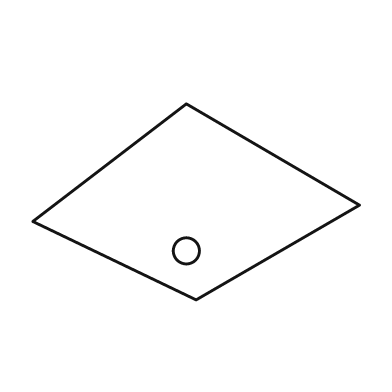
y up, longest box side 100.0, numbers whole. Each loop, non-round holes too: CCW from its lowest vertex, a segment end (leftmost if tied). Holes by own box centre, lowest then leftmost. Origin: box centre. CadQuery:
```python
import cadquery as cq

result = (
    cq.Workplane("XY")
    .moveTo(0.0, -30.0)
    .lineTo(50.0, -1.0)
    .lineTo(-3.0, 30.0)
    .lineTo(-50.0, -6.0)
    .close()
    .moveTo(-3.0, -15.0)
    .circle(4.0)
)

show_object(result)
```